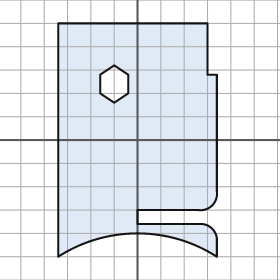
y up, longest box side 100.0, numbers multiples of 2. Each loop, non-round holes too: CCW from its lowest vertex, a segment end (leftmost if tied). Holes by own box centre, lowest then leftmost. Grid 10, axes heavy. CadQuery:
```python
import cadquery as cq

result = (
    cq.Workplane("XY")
    .moveTo(-34.0, -50.0)
    .threePointArc((0.0, -40.0), (34.0, -50.0))
    .lineTo(34.0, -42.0)
    .threePointArc((32.0, -38.0), (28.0, -36.0))
    .lineTo(0.0, -36.0)
    .lineTo(0.0, -30.0)
    .lineTo(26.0, -30.0)
    .threePointArc((32.0, -28.0), (34.0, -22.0))
    .lineTo(34.0, 28.0)
    .lineTo(30.0, 28.0)
    .lineTo(30.0, 50.0)
    .lineTo(-34.0, 50.0)
    .close()
    .moveTo(-10.0, 16.0)
    .lineTo(-4.0, 20.0)
    .lineTo(-4.0, 28.0)
    .lineTo(-10.0, 32.0)
    .lineTo(-16.0, 28.0)
    .lineTo(-16.0, 20.0)
    .close()
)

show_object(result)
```